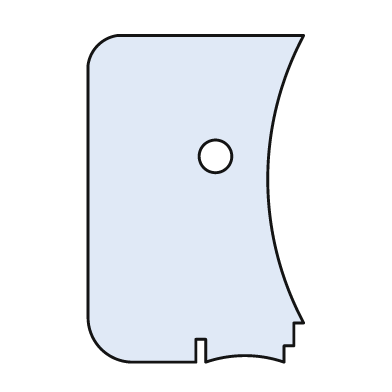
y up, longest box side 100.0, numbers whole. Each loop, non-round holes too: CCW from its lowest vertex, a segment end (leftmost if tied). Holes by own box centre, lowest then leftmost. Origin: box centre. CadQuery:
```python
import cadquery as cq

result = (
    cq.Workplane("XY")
    .moveTo(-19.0, -50.0)
    .lineTo(0.0, -50.0)
    .lineTo(0.0, -43.0)
    .lineTo(3.0, -43.0)
    .lineTo(3.0, -50.0)
    .threePointArc((15.0, -48.0), (27.0, -50.0))
    .lineTo(27.0, -45.0)
    .lineTo(30.0, -45.0)
    .lineTo(30.0, -38.0)
    .lineTo(33.0, -38.0)
    .threePointArc((22.0, 6.0), (33.0, 50.0))
    .lineTo(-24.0, 50.0)
    .threePointArc((-30.0, 47.0), (-33.0, 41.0))
    .lineTo(-33.0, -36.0)
    .threePointArc((-29.0, -46.0), (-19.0, -50.0))
    .close()
    .moveTo(6.0, 13.0)
    .circle(5.0)
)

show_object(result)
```